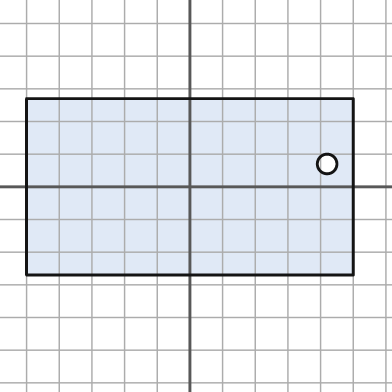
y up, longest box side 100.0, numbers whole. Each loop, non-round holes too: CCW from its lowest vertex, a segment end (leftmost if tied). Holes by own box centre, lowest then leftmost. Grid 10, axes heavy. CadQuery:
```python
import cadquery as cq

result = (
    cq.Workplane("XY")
    .moveTo(-50.0, -27.0)
    .lineTo(50.0, -27.0)
    .lineTo(50.0, 27.0)
    .lineTo(-50.0, 27.0)
    .close()
    .moveTo(42.0, 7.0)
    .circle(3.0)
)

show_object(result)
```